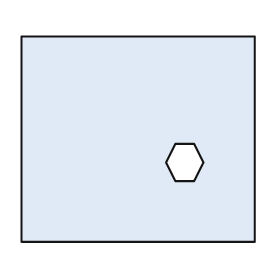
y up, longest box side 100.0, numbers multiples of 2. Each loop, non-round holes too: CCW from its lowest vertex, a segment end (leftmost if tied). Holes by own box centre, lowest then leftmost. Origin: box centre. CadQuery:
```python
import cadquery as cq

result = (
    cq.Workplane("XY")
    .moveTo(-50.0, -44.0)
    .lineTo(50.0, -44.0)
    .lineTo(50.0, 44.0)
    .lineTo(-50.0, 44.0)
    .close()
    .moveTo(16.0, -18.0)
    .lineTo(24.0, -18.0)
    .lineTo(28.0, -10.0)
    .lineTo(24.0, -2.0)
    .lineTo(16.0, -2.0)
    .lineTo(12.0, -10.0)
    .close()
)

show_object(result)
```